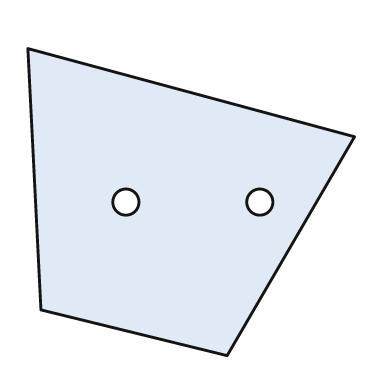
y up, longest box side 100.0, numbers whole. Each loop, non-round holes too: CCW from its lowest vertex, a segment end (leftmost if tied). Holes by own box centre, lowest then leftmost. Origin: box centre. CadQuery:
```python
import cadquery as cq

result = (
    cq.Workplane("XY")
    .moveTo(11.0, -47.0)
    .lineTo(50.0, 20.0)
    .lineTo(-50.0, 47.0)
    .lineTo(-46.0, -33.0)
    .close()
    .moveTo(-20.0, 0.0)
    .circle(4.0)
    .moveTo(21.0, 0.0)
    .circle(4.0)
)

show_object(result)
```